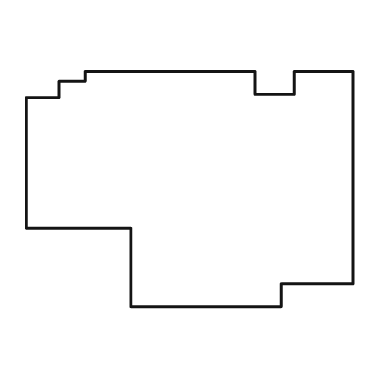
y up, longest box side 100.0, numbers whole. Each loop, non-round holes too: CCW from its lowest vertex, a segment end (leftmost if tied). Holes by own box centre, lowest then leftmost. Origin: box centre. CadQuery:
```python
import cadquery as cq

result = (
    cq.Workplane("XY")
    .moveTo(-18.0, -36.0)
    .lineTo(28.0, -36.0)
    .lineTo(28.0, -29.0)
    .lineTo(50.0, -29.0)
    .lineTo(50.0, 36.0)
    .lineTo(32.0, 36.0)
    .lineTo(32.0, 29.0)
    .lineTo(20.0, 29.0)
    .lineTo(20.0, 36.0)
    .lineTo(-32.0, 36.0)
    .lineTo(-32.0, 33.0)
    .lineTo(-40.0, 33.0)
    .lineTo(-40.0, 28.0)
    .lineTo(-50.0, 28.0)
    .lineTo(-50.0, -12.0)
    .lineTo(-18.0, -12.0)
    .close()
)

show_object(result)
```